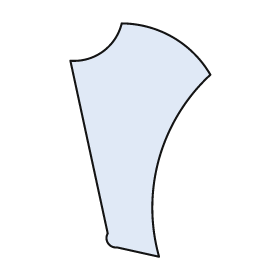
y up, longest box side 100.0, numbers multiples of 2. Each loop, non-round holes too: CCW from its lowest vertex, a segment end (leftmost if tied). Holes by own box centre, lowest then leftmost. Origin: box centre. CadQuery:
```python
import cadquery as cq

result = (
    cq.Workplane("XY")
    .moveTo(8.0, -50.0)
    .threePointArc((8.0, -8.0), (30.0, 28.0))
    .threePointArc((14.0, 44.0), (-8.0, 50.0))
    .threePointArc((-16.0, 38.0), (-30.0, 34.0))
    .lineTo(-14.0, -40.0)
    .threePointArc((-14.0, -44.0), (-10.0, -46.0))
    .close()
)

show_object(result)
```